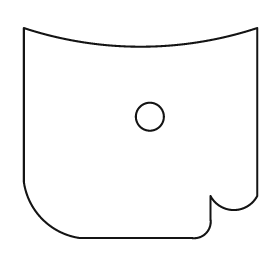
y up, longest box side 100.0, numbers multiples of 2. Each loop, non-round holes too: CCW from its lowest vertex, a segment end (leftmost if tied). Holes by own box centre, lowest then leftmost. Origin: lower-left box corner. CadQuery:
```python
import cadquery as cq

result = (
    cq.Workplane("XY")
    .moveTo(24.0, 0.0)
    .lineTo(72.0, 0.0)
    .threePointArc((78.0, 2.0), (80.0, 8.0))
    .lineTo(80.0, 18.0)
    .threePointArc((90.0, 12.0), (100.0, 18.0))
    .lineTo(100.0, 90.0)
    .threePointArc((50.0, 82.0), (0.0, 90.0))
    .lineTo(0.0, 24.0)
    .threePointArc((8.0, 8.0), (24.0, 0.0))
    .close()
    .moveTo(54.0, 52.0)
    .circle(6.0)
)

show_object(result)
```